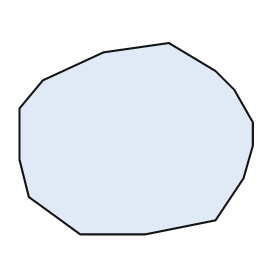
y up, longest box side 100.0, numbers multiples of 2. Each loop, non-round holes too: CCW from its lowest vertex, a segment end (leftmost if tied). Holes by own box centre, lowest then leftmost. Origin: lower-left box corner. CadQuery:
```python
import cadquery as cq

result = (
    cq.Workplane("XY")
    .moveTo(26.0, 0.0)
    .lineTo(54.0, 0.0)
    .lineTo(84.0, 6.0)
    .lineTo(96.0, 24.0)
    .lineTo(100.0, 38.0)
    .lineTo(100.0, 48.0)
    .lineTo(92.0, 62.0)
    .lineTo(84.0, 70.0)
    .lineTo(64.0, 82.0)
    .lineTo(36.0, 78.0)
    .lineTo(10.0, 66.0)
    .lineTo(0.0, 54.0)
    .lineTo(0.0, 32.0)
    .lineTo(4.0, 16.0)
    .close()
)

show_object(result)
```